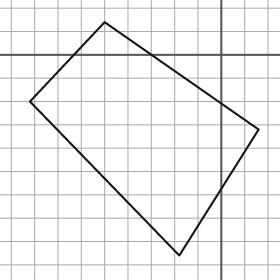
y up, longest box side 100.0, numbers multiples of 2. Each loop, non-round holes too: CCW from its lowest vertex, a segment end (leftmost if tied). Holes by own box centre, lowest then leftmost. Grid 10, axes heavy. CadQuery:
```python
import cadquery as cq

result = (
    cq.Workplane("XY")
    .moveTo(-18.0, -86.0)
    .lineTo(16.0, -32.0)
    .lineTo(-50.0, 14.0)
    .lineTo(-82.0, -20.0)
    .close()
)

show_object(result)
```